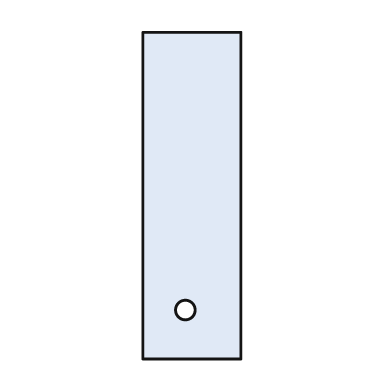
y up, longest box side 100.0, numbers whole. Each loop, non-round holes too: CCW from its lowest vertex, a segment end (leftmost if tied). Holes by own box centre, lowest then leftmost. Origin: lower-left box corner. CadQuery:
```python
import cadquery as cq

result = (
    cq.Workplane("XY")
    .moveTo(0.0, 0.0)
    .lineTo(30.0, 0.0)
    .lineTo(30.0, 100.0)
    .lineTo(0.0, 100.0)
    .close()
    .moveTo(13.0, 15.0)
    .circle(3.0)
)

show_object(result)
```